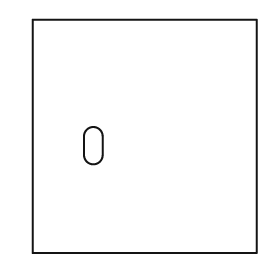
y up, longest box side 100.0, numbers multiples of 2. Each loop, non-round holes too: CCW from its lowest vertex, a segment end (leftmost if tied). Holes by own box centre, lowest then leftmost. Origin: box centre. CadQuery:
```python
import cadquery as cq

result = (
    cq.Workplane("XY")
    .moveTo(-48.0, -50.0)
    .lineTo(48.0, -50.0)
    .lineTo(48.0, 50.0)
    .lineTo(-48.0, 50.0)
    .close()
    .moveTo(-26.0, -8.0)
    .threePointArc((-22.0, -12.0), (-18.0, -8.0))
    .lineTo(-18.0, 0.0)
    .threePointArc((-22.0, 4.0), (-26.0, 0.0))
    .close()
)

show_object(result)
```